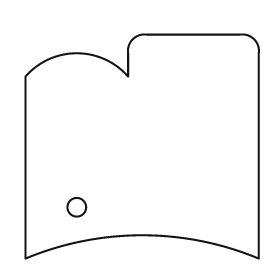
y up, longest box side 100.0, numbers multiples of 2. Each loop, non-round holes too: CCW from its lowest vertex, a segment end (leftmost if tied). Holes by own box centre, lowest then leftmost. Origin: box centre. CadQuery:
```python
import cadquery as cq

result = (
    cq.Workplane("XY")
    .moveTo(-50.0, -48.0)
    .threePointArc((0.0, -38.0), (50.0, -48.0))
    .lineTo(50.0, 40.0)
    .threePointArc((48.0, 46.0), (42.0, 48.0))
    .lineTo(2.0, 48.0)
    .threePointArc((-4.0, 46.0), (-6.0, 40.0))
    .lineTo(-6.0, 30.0)
    .threePointArc((-28.0, 40.0), (-50.0, 30.0))
    .close()
    .moveTo(-28.0, -26.0)
    .circle(4.0)
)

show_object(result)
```